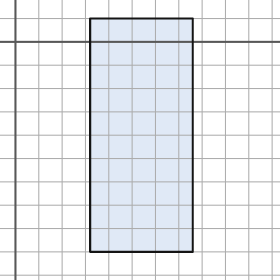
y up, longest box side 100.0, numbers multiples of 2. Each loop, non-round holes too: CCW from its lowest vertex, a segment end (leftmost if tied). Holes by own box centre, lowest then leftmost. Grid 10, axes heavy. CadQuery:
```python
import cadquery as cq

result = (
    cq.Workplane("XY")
    .moveTo(32.0, -90.0)
    .lineTo(76.0, -90.0)
    .lineTo(76.0, 10.0)
    .lineTo(32.0, 10.0)
    .close()
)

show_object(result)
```